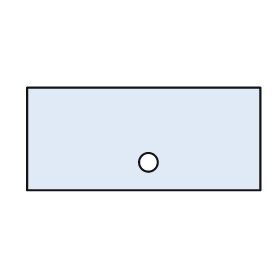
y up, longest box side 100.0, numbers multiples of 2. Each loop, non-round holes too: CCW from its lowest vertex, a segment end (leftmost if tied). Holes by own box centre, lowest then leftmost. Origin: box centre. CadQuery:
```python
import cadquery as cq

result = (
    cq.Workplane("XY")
    .moveTo(-50.0, -22.0)
    .lineTo(50.0, -22.0)
    .lineTo(50.0, 22.0)
    .lineTo(-50.0, 22.0)
    .close()
    .moveTo(2.0, -10.0)
    .circle(4.0)
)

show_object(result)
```